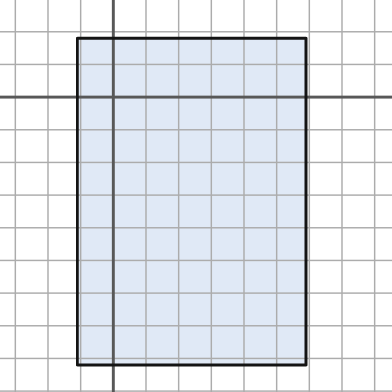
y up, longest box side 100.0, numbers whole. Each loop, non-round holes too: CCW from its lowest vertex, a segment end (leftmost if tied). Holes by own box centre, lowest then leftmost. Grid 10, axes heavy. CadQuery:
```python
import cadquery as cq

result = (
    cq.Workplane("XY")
    .moveTo(-11.0, -82.0)
    .lineTo(59.0, -82.0)
    .lineTo(59.0, 18.0)
    .lineTo(-11.0, 18.0)
    .close()
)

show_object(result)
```